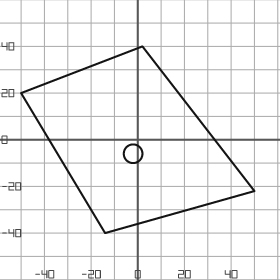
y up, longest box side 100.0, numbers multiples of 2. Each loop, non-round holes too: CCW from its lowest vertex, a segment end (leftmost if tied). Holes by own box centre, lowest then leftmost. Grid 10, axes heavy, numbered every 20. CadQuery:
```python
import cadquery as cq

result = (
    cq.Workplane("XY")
    .moveTo(-14.0, -40.0)
    .lineTo(50.0, -22.0)
    .lineTo(2.0, 40.0)
    .lineTo(-50.0, 20.0)
    .close()
    .moveTo(-2.0, -6.0)
    .circle(4.0)
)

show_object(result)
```